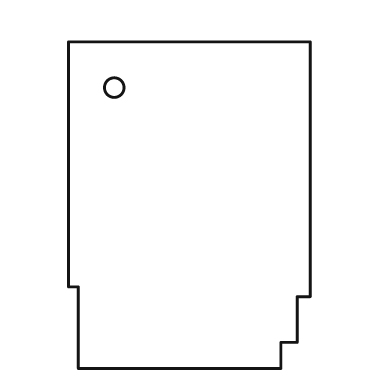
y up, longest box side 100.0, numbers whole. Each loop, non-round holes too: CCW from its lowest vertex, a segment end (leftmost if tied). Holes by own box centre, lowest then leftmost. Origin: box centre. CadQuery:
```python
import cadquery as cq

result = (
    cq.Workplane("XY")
    .moveTo(-34.0, -50.0)
    .lineTo(28.0, -50.0)
    .lineTo(28.0, -42.0)
    .lineTo(33.0, -42.0)
    .lineTo(33.0, -28.0)
    .lineTo(37.0, -28.0)
    .lineTo(37.0, 50.0)
    .lineTo(-37.0, 50.0)
    .lineTo(-37.0, -25.0)
    .lineTo(-34.0, -25.0)
    .close()
    .moveTo(-23.0, 36.0)
    .circle(3.0)
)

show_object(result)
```